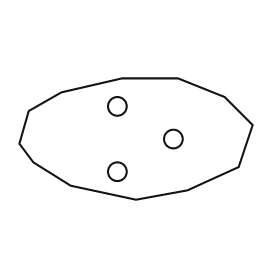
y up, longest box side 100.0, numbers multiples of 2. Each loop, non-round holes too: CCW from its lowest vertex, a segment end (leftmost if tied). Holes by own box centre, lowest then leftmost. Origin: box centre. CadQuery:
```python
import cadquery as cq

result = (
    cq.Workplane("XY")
    .moveTo(0.0, -26.0)
    .lineTo(22.0, -22.0)
    .lineTo(44.0, -12.0)
    .lineTo(50.0, 6.0)
    .lineTo(38.0, 18.0)
    .lineTo(18.0, 26.0)
    .lineTo(-6.0, 26.0)
    .lineTo(-32.0, 20.0)
    .lineTo(-46.0, 12.0)
    .lineTo(-50.0, -2.0)
    .lineTo(-44.0, -10.0)
    .lineTo(-28.0, -20.0)
    .close()
    .moveTo(-8.0, -14.0)
    .circle(4.0)
    .moveTo(16.0, 0.0)
    .circle(4.0)
    .moveTo(-8.0, 14.0)
    .circle(4.0)
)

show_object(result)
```